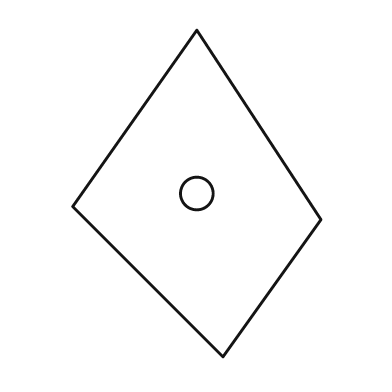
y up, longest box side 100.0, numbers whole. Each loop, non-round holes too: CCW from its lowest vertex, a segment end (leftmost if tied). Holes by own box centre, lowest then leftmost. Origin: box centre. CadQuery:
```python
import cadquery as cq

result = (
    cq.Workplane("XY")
    .moveTo(8.0, -50.0)
    .lineTo(38.0, -8.0)
    .lineTo(0.0, 50.0)
    .lineTo(-38.0, -4.0)
    .close()
    .moveTo(0.0, 0.0)
    .circle(5.0)
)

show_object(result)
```